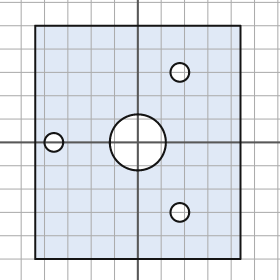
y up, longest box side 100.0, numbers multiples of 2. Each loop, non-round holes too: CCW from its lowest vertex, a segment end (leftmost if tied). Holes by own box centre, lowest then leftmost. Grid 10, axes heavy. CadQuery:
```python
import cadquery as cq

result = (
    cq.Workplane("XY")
    .moveTo(-44.0, -50.0)
    .lineTo(44.0, -50.0)
    .lineTo(44.0, 50.0)
    .lineTo(-44.0, 50.0)
    .close()
    .moveTo(18.0, -30.0)
    .circle(4.0)
    .moveTo(-36.0, 0.0)
    .circle(4.0)
    .moveTo(0.0, 0.0)
    .circle(12.0)
    .moveTo(18.0, 30.0)
    .circle(4.0)
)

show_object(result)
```